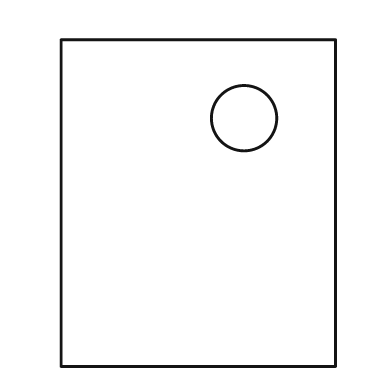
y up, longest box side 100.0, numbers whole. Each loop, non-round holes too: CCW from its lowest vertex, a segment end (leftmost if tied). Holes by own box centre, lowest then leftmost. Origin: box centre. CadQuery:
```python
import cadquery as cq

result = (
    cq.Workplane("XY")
    .moveTo(-42.0, -50.0)
    .lineTo(42.0, -50.0)
    .lineTo(42.0, 50.0)
    .lineTo(-42.0, 50.0)
    .close()
    .moveTo(14.0, 26.0)
    .circle(10.0)
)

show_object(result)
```